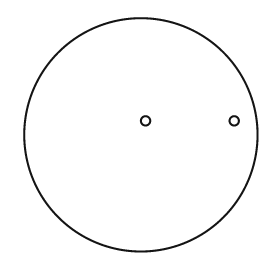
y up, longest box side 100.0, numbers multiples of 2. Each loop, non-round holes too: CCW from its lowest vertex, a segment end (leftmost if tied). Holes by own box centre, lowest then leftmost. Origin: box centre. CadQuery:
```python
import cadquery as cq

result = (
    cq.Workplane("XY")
    .moveTo(0.0, 0.0)
    .circle(50.0)
    .moveTo(2.0, 6.0)
    .circle(2.0)
    .moveTo(40.0, 6.0)
    .circle(2.0)
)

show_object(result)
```